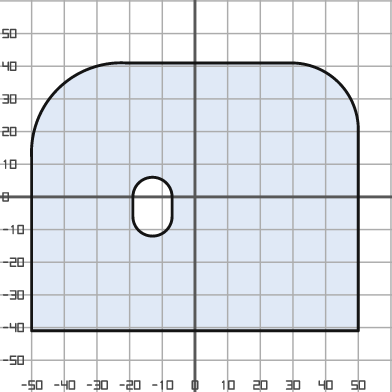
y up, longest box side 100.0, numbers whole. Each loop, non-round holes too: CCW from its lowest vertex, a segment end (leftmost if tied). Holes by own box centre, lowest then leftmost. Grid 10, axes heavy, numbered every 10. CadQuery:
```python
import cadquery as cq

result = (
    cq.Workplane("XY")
    .moveTo(-50.0, -41.0)
    .lineTo(50.0, -41.0)
    .lineTo(50.0, 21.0)
    .threePointArc((44.0, 35.0), (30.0, 41.0))
    .lineTo(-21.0, 41.0)
    .threePointArc((-42.0, 33.0), (-50.0, 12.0))
    .close()
    .moveTo(-19.0, -6.0)
    .threePointArc((-13.0, -12.0), (-7.0, -6.0))
    .lineTo(-7.0, 0.0)
    .threePointArc((-13.0, 6.0), (-19.0, 0.0))
    .close()
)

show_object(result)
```